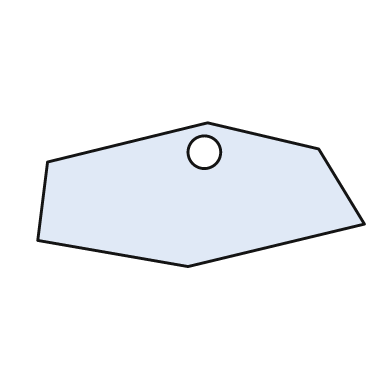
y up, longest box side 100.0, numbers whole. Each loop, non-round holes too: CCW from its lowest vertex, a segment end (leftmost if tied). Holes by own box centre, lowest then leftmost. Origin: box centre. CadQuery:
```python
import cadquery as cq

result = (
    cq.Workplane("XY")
    .moveTo(-4.0, -22.0)
    .lineTo(50.0, -9.0)
    .lineTo(36.0, 14.0)
    .lineTo(2.0, 22.0)
    .lineTo(-47.0, 10.0)
    .lineTo(-50.0, -14.0)
    .close()
    .moveTo(1.0, 13.0)
    .circle(5.0)
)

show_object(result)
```